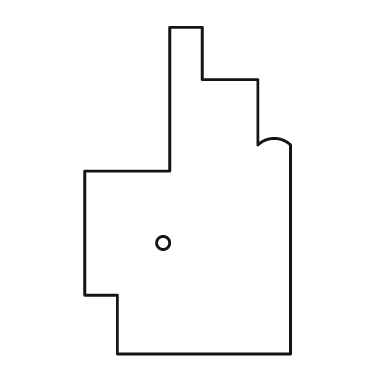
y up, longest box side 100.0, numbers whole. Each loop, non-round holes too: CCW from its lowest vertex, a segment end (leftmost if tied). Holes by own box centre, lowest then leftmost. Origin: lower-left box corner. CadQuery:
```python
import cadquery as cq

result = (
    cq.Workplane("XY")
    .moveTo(10.0, 0.0)
    .lineTo(63.0, 0.0)
    .lineTo(63.0, 64.0)
    .threePointArc((58.0, 66.0), (53.0, 64.0))
    .lineTo(53.0, 84.0)
    .lineTo(36.0, 84.0)
    .lineTo(36.0, 100.0)
    .lineTo(26.0, 100.0)
    .lineTo(26.0, 56.0)
    .lineTo(0.0, 56.0)
    .lineTo(0.0, 18.0)
    .lineTo(10.0, 18.0)
    .close()
    .moveTo(24.0, 34.0)
    .circle(2.0)
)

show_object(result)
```